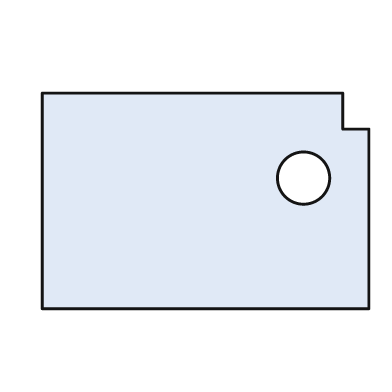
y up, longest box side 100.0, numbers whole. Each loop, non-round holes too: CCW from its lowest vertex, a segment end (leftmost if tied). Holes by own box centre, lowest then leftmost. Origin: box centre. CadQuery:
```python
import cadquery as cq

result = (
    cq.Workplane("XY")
    .moveTo(-50.0, -33.0)
    .lineTo(50.0, -33.0)
    .lineTo(50.0, 22.0)
    .lineTo(42.0, 22.0)
    .lineTo(42.0, 33.0)
    .lineTo(-50.0, 33.0)
    .close()
    .moveTo(30.0, 7.0)
    .circle(8.0)
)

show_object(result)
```